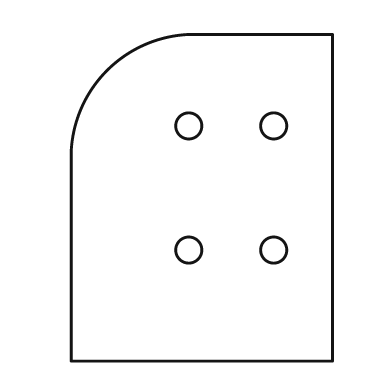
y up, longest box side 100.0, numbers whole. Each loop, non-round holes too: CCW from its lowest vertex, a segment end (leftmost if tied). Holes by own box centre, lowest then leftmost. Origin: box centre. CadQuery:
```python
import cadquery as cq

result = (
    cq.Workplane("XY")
    .moveTo(-40.0, -50.0)
    .lineTo(40.0, -50.0)
    .lineTo(40.0, 50.0)
    .lineTo(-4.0, 50.0)
    .threePointArc((-29.0, 39.0), (-40.0, 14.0))
    .close()
    .moveTo(-4.0, -16.0)
    .circle(4.0)
    .moveTo(22.0, -16.0)
    .circle(4.0)
    .moveTo(-4.0, 22.0)
    .circle(4.0)
    .moveTo(22.0, 22.0)
    .circle(4.0)
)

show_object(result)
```